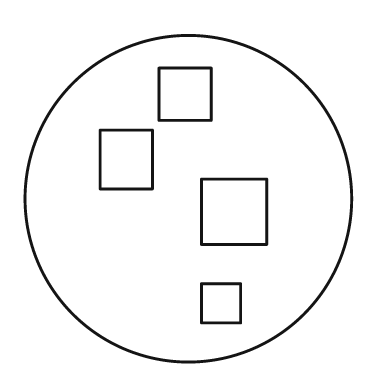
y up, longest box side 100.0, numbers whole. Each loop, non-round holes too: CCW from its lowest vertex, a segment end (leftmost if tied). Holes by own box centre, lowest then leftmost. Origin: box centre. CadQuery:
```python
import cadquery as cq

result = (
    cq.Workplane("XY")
    .moveTo(0.0, 0.0)
    .circle(50.0)
    .moveTo(4.0, -38.0)
    .lineTo(16.0, -38.0)
    .lineTo(16.0, -26.0)
    .lineTo(4.0, -26.0)
    .close()
    .moveTo(4.0, -14.0)
    .lineTo(24.0, -14.0)
    .lineTo(24.0, 6.0)
    .lineTo(4.0, 6.0)
    .close()
    .moveTo(-27.0, 3.0)
    .lineTo(-11.0, 3.0)
    .lineTo(-11.0, 21.0)
    .lineTo(-27.0, 21.0)
    .close()
    .moveTo(-9.0, 24.0)
    .lineTo(7.0, 24.0)
    .lineTo(7.0, 40.0)
    .lineTo(-9.0, 40.0)
    .close()
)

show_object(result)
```